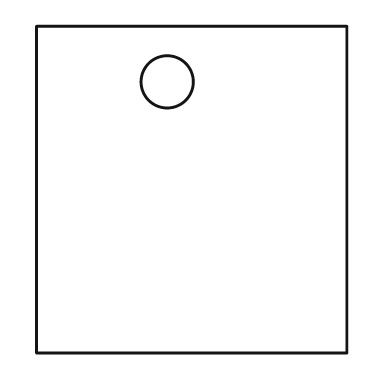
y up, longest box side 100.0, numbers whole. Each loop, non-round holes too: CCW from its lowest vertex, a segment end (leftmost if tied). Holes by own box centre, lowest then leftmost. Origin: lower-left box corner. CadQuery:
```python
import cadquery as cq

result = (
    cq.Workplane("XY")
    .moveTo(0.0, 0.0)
    .lineTo(95.0, 0.0)
    .lineTo(95.0, 100.0)
    .lineTo(0.0, 100.0)
    .close()
    .moveTo(40.0, 83.0)
    .circle(8.0)
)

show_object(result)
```